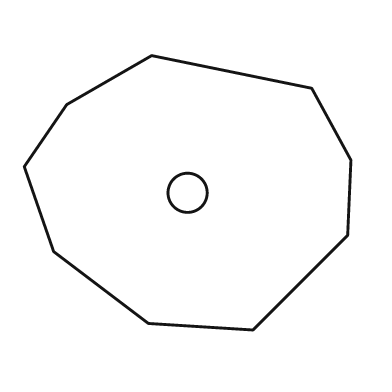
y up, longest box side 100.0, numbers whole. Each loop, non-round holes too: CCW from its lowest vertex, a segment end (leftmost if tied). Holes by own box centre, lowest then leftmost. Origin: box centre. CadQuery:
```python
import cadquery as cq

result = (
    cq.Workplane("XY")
    .moveTo(20.0, -42.0)
    .lineTo(49.0, -13.0)
    .lineTo(50.0, 10.0)
    .lineTo(38.0, 32.0)
    .lineTo(-11.0, 42.0)
    .lineTo(-37.0, 27.0)
    .lineTo(-50.0, 8.0)
    .lineTo(-41.0, -18.0)
    .lineTo(-12.0, -40.0)
    .close()
    .moveTo(0.0, 0.0)
    .circle(6.0)
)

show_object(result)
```